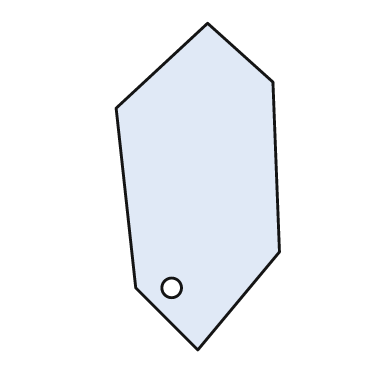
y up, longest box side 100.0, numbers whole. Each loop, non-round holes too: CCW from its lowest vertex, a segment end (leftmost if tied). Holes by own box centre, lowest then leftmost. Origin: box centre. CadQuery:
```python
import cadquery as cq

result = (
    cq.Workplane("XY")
    .moveTo(0.0, -50.0)
    .lineTo(25.0, -20.0)
    .lineTo(23.0, 32.0)
    .lineTo(3.0, 50.0)
    .lineTo(-25.0, 24.0)
    .lineTo(-19.0, -31.0)
    .close()
    .moveTo(-8.0, -31.0)
    .circle(3.0)
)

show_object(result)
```